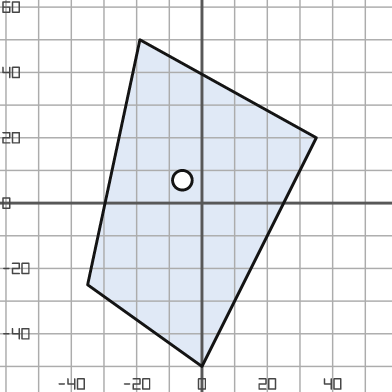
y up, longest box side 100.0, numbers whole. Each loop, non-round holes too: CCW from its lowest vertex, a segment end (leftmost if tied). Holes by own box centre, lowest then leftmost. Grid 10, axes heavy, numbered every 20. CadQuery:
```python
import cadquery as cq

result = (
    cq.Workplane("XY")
    .moveTo(0.0, -50.0)
    .lineTo(35.0, 20.0)
    .lineTo(-19.0, 50.0)
    .lineTo(-35.0, -25.0)
    .close()
    .moveTo(-6.0, 7.0)
    .circle(3.0)
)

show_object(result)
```